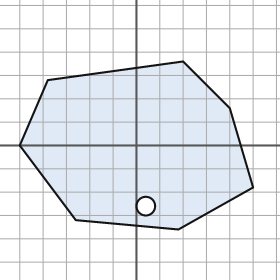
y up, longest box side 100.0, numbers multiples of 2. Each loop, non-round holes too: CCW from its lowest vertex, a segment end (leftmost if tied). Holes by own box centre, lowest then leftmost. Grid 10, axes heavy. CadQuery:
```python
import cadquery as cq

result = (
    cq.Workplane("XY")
    .moveTo(18.0, -36.0)
    .lineTo(50.0, -18.0)
    .lineTo(40.0, 16.0)
    .lineTo(20.0, 36.0)
    .lineTo(-38.0, 28.0)
    .lineTo(-50.0, 0.0)
    .lineTo(-26.0, -32.0)
    .close()
    .moveTo(4.0, -26.0)
    .circle(4.0)
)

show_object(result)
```